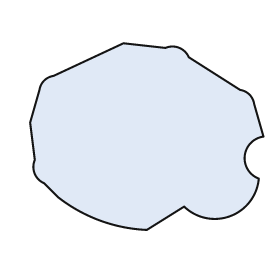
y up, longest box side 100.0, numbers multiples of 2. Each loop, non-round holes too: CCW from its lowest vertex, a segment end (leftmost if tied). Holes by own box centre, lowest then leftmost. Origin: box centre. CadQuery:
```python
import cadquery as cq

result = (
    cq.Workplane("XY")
    .moveTo(0.0, -40.0)
    .lineTo(16.0, -30.0)
    .threePointArc((36.0, -34.0), (48.0, -18.0))
    .threePointArc((42.0, -8.0), (50.0, 0.0))
    .lineTo(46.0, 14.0)
    .threePointArc((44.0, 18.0), (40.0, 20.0))
    .lineTo(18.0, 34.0)
    .threePointArc((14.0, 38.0), (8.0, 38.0))
    .lineTo(-10.0, 40.0)
    .lineTo(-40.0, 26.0)
    .threePointArc((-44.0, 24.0), (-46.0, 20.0))
    .lineTo(-50.0, 6.0)
    .lineTo(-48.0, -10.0)
    .threePointArc((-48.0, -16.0), (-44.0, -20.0))
    .lineTo(-38.0, -26.0)
    .threePointArc((-20.0, -36.0), (0.0, -40.0))
    .close()
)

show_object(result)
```